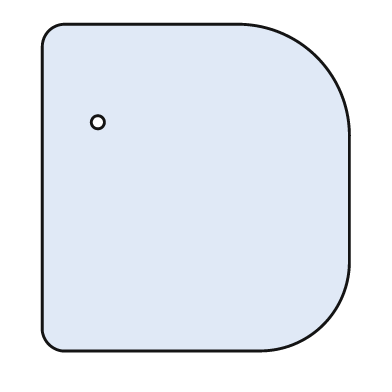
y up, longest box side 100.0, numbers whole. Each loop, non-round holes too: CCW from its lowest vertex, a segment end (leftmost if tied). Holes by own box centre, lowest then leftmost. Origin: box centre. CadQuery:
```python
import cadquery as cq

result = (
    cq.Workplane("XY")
    .moveTo(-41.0, -50.0)
    .lineTo(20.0, -50.0)
    .threePointArc((39.0, -42.0), (47.0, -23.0))
    .lineTo(47.0, 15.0)
    .threePointArc((37.0, 40.0), (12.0, 50.0))
    .lineTo(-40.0, 50.0)
    .threePointArc((-45.0, 48.0), (-47.0, 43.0))
    .lineTo(-47.0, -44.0)
    .threePointArc((-45.0, -48.0), (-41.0, -50.0))
    .close()
    .moveTo(-30.0, 20.0)
    .circle(2.0)
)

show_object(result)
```